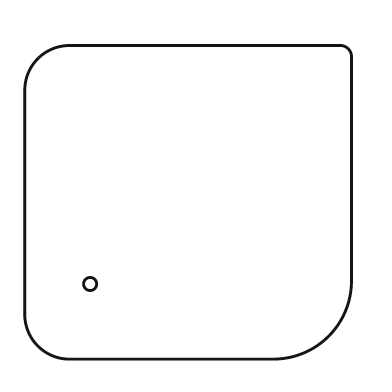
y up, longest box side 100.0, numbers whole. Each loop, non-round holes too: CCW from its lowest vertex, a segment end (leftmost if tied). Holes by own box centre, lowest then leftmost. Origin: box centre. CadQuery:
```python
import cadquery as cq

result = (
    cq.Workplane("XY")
    .moveTo(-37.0, -48.0)
    .lineTo(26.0, -48.0)
    .threePointArc((43.0, -41.0), (50.0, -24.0))
    .lineTo(50.0, 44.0)
    .threePointArc((49.0, 47.0), (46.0, 48.0))
    .lineTo(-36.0, 48.0)
    .threePointArc((-46.0, 44.0), (-50.0, 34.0))
    .lineTo(-50.0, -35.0)
    .threePointArc((-46.0, -44.0), (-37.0, -48.0))
    .close()
    .moveTo(-30.0, -25.0)
    .circle(2.0)
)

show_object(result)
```